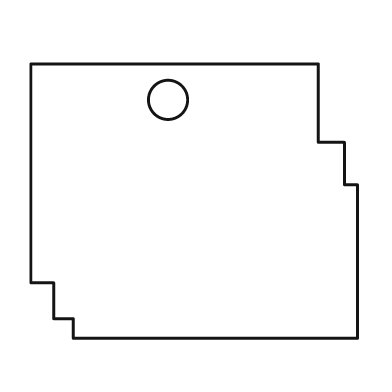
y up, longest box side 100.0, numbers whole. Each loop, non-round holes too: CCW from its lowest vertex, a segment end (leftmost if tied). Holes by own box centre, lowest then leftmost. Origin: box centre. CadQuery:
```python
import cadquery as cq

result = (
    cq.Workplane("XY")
    .moveTo(-37.0, -42.0)
    .lineTo(50.0, -42.0)
    .lineTo(50.0, 5.0)
    .lineTo(46.0, 5.0)
    .lineTo(46.0, 18.0)
    .lineTo(38.0, 18.0)
    .lineTo(38.0, 42.0)
    .lineTo(-50.0, 42.0)
    .lineTo(-50.0, -25.0)
    .lineTo(-43.0, -25.0)
    .lineTo(-43.0, -36.0)
    .lineTo(-37.0, -36.0)
    .close()
    .moveTo(-8.0, 31.0)
    .circle(6.0)
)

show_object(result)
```